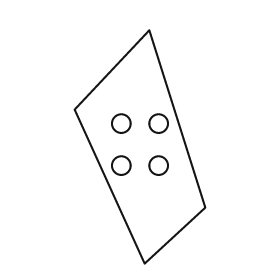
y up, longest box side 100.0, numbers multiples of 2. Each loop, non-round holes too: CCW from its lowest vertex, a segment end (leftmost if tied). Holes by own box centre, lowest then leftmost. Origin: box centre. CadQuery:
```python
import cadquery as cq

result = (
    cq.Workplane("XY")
    .moveTo(2.0, -50.0)
    .lineTo(28.0, -26.0)
    .lineTo(4.0, 50.0)
    .lineTo(-28.0, 16.0)
    .close()
    .moveTo(-8.0, -8.0)
    .circle(4.0)
    .moveTo(8.0, -8.0)
    .circle(4.0)
    .moveTo(-8.0, 10.0)
    .circle(4.0)
    .moveTo(8.0, 10.0)
    .circle(4.0)
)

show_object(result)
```